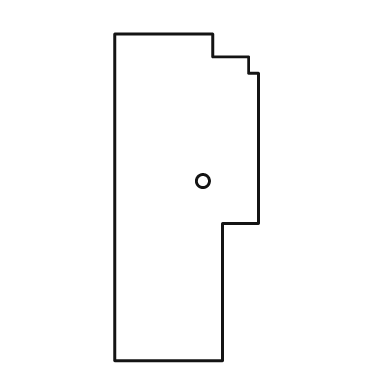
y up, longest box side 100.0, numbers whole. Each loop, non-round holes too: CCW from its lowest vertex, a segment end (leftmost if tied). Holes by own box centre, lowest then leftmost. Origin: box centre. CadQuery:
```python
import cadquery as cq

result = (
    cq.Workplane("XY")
    .moveTo(-22.0, -50.0)
    .lineTo(11.0, -50.0)
    .lineTo(11.0, -8.0)
    .lineTo(22.0, -8.0)
    .lineTo(22.0, 38.0)
    .lineTo(19.0, 38.0)
    .lineTo(19.0, 43.0)
    .lineTo(8.0, 43.0)
    .lineTo(8.0, 50.0)
    .lineTo(-22.0, 50.0)
    .close()
    .moveTo(5.0, 5.0)
    .circle(2.0)
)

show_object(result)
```